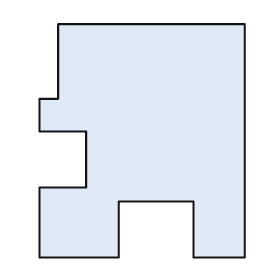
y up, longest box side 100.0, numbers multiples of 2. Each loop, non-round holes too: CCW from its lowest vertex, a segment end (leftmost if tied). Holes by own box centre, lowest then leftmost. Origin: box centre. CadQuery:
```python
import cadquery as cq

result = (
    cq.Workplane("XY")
    .moveTo(-44.0, -50.0)
    .lineTo(-10.0, -50.0)
    .lineTo(-10.0, -26.0)
    .lineTo(22.0, -26.0)
    .lineTo(22.0, -50.0)
    .lineTo(44.0, -50.0)
    .lineTo(44.0, 50.0)
    .lineTo(-36.0, 50.0)
    .lineTo(-36.0, 18.0)
    .lineTo(-44.0, 18.0)
    .lineTo(-44.0, 4.0)
    .lineTo(-24.0, 4.0)
    .lineTo(-24.0, -20.0)
    .lineTo(-44.0, -20.0)
    .close()
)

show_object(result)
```